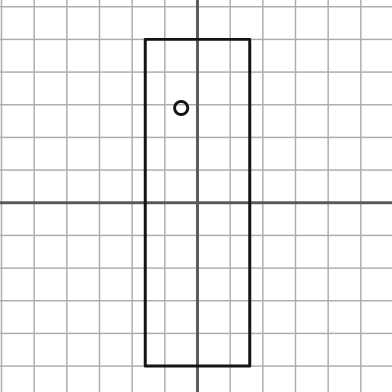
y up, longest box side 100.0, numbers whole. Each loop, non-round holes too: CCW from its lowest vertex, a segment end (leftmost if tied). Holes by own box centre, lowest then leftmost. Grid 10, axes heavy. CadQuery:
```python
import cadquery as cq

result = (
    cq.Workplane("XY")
    .moveTo(-16.0, -50.0)
    .lineTo(16.0, -50.0)
    .lineTo(16.0, 50.0)
    .lineTo(-16.0, 50.0)
    .close()
    .moveTo(-5.0, 29.0)
    .circle(2.0)
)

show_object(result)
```